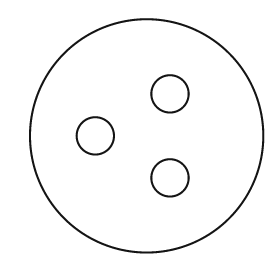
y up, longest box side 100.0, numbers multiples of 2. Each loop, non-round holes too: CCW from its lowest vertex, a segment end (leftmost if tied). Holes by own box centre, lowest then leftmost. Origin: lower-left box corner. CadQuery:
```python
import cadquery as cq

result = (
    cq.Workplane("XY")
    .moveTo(50.0, 50.0)
    .circle(50.0)
    .moveTo(60.0, 32.0)
    .circle(8.0)
    .moveTo(28.0, 50.0)
    .circle(8.0)
    .moveTo(60.0, 68.0)
    .circle(8.0)
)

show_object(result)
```